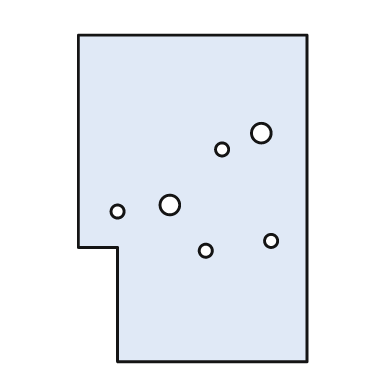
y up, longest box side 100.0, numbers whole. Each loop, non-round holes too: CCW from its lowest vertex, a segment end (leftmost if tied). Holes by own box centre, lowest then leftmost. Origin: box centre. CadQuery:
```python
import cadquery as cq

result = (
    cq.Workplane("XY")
    .moveTo(-23.0, -50.0)
    .lineTo(35.0, -50.0)
    .lineTo(35.0, 50.0)
    .lineTo(-35.0, 50.0)
    .lineTo(-35.0, -15.0)
    .lineTo(-23.0, -15.0)
    .close()
    .moveTo(4.0, -16.0)
    .circle(2.0)
    .moveTo(24.0, -13.0)
    .circle(2.0)
    .moveTo(-23.0, -4.0)
    .circle(2.0)
    .moveTo(-7.0, -2.0)
    .circle(3.0)
    .moveTo(9.0, 15.0)
    .circle(2.0)
    .moveTo(21.0, 20.0)
    .circle(3.0)
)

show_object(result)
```